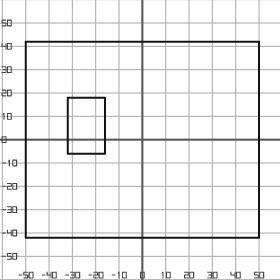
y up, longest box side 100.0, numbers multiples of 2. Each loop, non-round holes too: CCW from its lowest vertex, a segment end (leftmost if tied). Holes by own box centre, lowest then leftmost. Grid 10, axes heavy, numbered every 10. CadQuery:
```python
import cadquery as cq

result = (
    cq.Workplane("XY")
    .moveTo(-50.0, -42.0)
    .lineTo(50.0, -42.0)
    .lineTo(50.0, 42.0)
    .lineTo(-50.0, 42.0)
    .close()
    .moveTo(-32.0, -6.0)
    .lineTo(-16.0, -6.0)
    .lineTo(-16.0, 18.0)
    .lineTo(-32.0, 18.0)
    .close()
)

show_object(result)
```